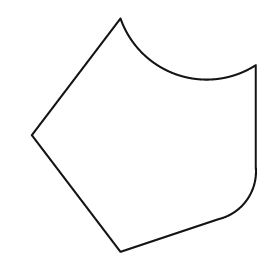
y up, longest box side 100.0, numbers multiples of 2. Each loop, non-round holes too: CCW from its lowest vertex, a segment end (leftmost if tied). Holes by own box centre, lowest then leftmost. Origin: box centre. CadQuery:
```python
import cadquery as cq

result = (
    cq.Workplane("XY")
    .moveTo(-10.0, -50.0)
    .lineTo(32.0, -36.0)
    .threePointArc((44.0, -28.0), (48.0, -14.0))
    .lineTo(48.0, 30.0)
    .threePointArc((14.0, 26.0), (-10.0, 50.0))
    .lineTo(-48.0, 0.0)
    .close()
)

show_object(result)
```